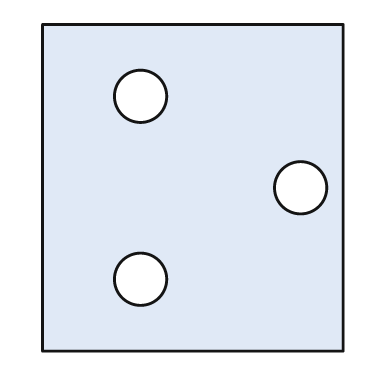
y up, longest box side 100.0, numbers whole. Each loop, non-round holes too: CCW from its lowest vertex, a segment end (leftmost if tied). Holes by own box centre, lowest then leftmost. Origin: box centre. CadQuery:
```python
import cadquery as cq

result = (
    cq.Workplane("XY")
    .moveTo(-46.0, -50.0)
    .lineTo(46.0, -50.0)
    .lineTo(46.0, 50.0)
    .lineTo(-46.0, 50.0)
    .close()
    .moveTo(-16.0, -28.0)
    .circle(8.0)
    .moveTo(33.0, 0.0)
    .circle(8.0)
    .moveTo(-16.0, 28.0)
    .circle(8.0)
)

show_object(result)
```